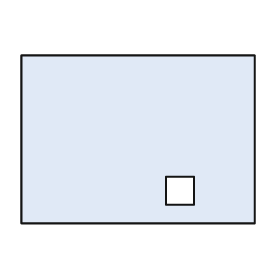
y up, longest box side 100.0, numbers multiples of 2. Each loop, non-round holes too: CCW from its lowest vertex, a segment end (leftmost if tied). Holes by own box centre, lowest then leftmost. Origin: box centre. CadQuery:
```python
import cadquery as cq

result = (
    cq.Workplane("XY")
    .moveTo(-50.0, -36.0)
    .lineTo(50.0, -36.0)
    .lineTo(50.0, 36.0)
    .lineTo(-50.0, 36.0)
    .close()
    .moveTo(12.0, -28.0)
    .lineTo(24.0, -28.0)
    .lineTo(24.0, -16.0)
    .lineTo(12.0, -16.0)
    .close()
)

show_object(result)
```